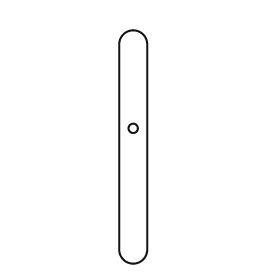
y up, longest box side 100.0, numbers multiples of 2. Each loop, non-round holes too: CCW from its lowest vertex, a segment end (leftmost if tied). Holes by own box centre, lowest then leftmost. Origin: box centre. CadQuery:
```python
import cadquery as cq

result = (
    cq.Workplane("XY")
    .moveTo(-6.0, -44.0)
    .threePointArc((0.0, -50.0), (6.0, -44.0))
    .lineTo(6.0, 44.0)
    .threePointArc((0.0, 50.0), (-6.0, 44.0))
    .close()
    .moveTo(0.0, 8.0)
    .circle(2.0)
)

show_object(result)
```